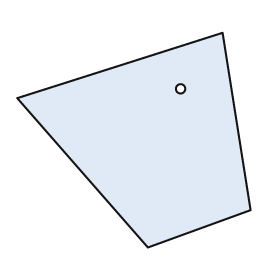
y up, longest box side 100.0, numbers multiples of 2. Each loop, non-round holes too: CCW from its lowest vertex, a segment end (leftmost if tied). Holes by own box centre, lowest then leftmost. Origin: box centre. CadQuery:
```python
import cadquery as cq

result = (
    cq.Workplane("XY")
    .moveTo(6.0, -46.0)
    .lineTo(50.0, -30.0)
    .lineTo(38.0, 46.0)
    .lineTo(-50.0, 18.0)
    .close()
    .moveTo(20.0, 22.0)
    .circle(2.0)
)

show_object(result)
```